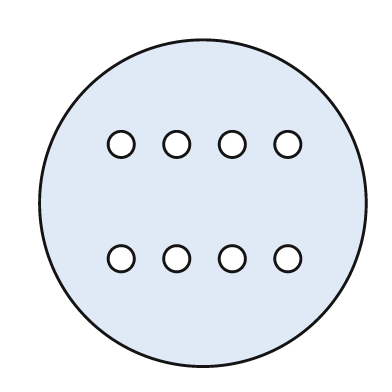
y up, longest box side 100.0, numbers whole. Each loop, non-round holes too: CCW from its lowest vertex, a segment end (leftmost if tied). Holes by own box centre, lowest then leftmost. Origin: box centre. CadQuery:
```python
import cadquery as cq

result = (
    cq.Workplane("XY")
    .moveTo(0.0, 0.0)
    .circle(50.0)
    .moveTo(-25.0, -17.0)
    .circle(4.0)
    .moveTo(-8.0, -17.0)
    .circle(4.0)
    .moveTo(9.0, -17.0)
    .circle(4.0)
    .moveTo(26.0, -17.0)
    .circle(4.0)
    .moveTo(-25.0, 18.0)
    .circle(4.0)
    .moveTo(-8.0, 18.0)
    .circle(4.0)
    .moveTo(9.0, 18.0)
    .circle(4.0)
    .moveTo(26.0, 18.0)
    .circle(4.0)
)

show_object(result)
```